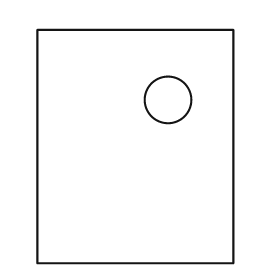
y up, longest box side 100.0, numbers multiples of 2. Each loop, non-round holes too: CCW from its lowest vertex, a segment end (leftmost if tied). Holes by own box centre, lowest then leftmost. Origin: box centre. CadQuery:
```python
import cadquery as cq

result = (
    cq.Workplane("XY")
    .moveTo(-42.0, -50.0)
    .lineTo(42.0, -50.0)
    .lineTo(42.0, 50.0)
    .lineTo(-42.0, 50.0)
    .close()
    .moveTo(14.0, 20.0)
    .circle(10.0)
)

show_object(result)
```